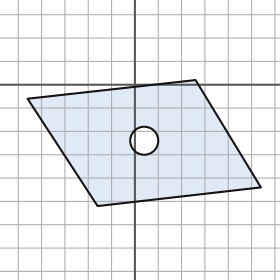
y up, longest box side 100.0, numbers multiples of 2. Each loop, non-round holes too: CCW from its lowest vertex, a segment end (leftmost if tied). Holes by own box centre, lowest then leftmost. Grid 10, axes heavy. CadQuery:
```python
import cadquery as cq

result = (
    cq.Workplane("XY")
    .moveTo(-16.0, -52.0)
    .lineTo(54.0, -44.0)
    .lineTo(26.0, 2.0)
    .lineTo(-46.0, -6.0)
    .close()
    .moveTo(4.0, -24.0)
    .circle(6.0)
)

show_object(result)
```